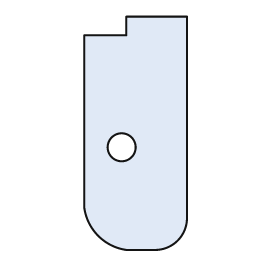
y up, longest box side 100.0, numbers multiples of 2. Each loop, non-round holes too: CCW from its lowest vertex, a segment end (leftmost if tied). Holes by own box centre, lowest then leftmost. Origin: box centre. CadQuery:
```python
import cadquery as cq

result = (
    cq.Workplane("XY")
    .moveTo(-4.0, -50.0)
    .lineTo(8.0, -50.0)
    .threePointArc((18.0, -46.0), (22.0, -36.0))
    .lineTo(22.0, 50.0)
    .lineTo(-4.0, 50.0)
    .lineTo(-4.0, 42.0)
    .lineTo(-22.0, 42.0)
    .lineTo(-22.0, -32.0)
    .threePointArc((-16.0, -44.0), (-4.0, -50.0))
    .close()
    .moveTo(-6.0, -6.0)
    .circle(6.0)
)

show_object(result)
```